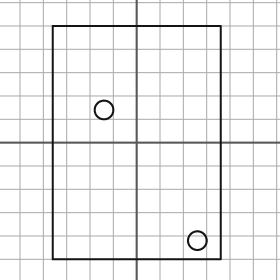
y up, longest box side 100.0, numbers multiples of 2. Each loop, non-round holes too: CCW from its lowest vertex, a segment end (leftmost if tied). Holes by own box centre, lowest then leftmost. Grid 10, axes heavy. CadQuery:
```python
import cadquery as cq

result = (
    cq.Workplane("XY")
    .moveTo(-36.0, -50.0)
    .lineTo(36.0, -50.0)
    .lineTo(36.0, 50.0)
    .lineTo(-36.0, 50.0)
    .close()
    .moveTo(26.0, -42.0)
    .circle(4.0)
    .moveTo(-14.0, 14.0)
    .circle(4.0)
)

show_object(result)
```